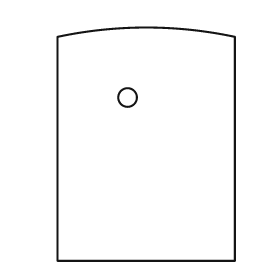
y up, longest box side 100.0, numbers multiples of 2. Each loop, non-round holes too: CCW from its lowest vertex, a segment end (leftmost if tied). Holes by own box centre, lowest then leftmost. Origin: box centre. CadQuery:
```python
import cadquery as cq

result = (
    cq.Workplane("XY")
    .moveTo(-38.0, -50.0)
    .lineTo(38.0, -50.0)
    .lineTo(38.0, 46.0)
    .threePointArc((0.0, 50.0), (-38.0, 46.0))
    .close()
    .moveTo(-8.0, 20.0)
    .circle(4.0)
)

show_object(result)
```